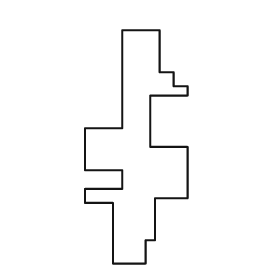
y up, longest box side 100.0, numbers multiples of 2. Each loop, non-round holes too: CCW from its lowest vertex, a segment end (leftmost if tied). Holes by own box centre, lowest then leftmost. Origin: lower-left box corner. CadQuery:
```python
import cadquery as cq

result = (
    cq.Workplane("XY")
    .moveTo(12.0, 0.0)
    .lineTo(26.0, 0.0)
    .lineTo(26.0, 10.0)
    .lineTo(30.0, 10.0)
    .lineTo(30.0, 28.0)
    .lineTo(44.0, 28.0)
    .lineTo(44.0, 50.0)
    .lineTo(28.0, 50.0)
    .lineTo(28.0, 72.0)
    .lineTo(44.0, 72.0)
    .lineTo(44.0, 76.0)
    .lineTo(38.0, 76.0)
    .lineTo(38.0, 82.0)
    .lineTo(32.0, 82.0)
    .lineTo(32.0, 100.0)
    .lineTo(16.0, 100.0)
    .lineTo(16.0, 58.0)
    .lineTo(0.0, 58.0)
    .lineTo(0.0, 40.0)
    .lineTo(16.0, 40.0)
    .lineTo(16.0, 32.0)
    .lineTo(0.0, 32.0)
    .lineTo(0.0, 26.0)
    .lineTo(12.0, 26.0)
    .close()
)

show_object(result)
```